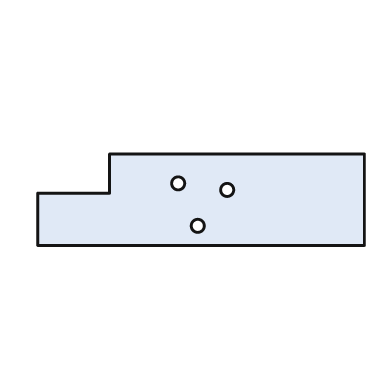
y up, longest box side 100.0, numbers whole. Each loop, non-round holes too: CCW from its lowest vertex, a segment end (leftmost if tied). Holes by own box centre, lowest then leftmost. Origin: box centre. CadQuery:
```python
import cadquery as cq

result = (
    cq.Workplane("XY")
    .moveTo(-50.0, -14.0)
    .lineTo(50.0, -14.0)
    .lineTo(50.0, 14.0)
    .lineTo(-28.0, 14.0)
    .lineTo(-28.0, 2.0)
    .lineTo(-50.0, 2.0)
    .close()
    .moveTo(-1.0, -8.0)
    .circle(2.0)
    .moveTo(8.0, 3.0)
    .circle(2.0)
    .moveTo(-7.0, 5.0)
    .circle(2.0)
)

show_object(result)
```